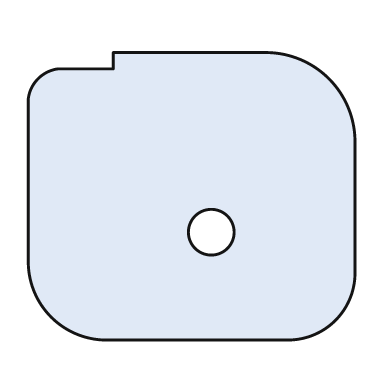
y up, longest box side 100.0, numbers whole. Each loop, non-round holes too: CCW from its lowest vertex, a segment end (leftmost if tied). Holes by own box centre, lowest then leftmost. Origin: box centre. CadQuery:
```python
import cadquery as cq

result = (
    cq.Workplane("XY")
    .moveTo(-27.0, -44.0)
    .lineTo(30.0, -44.0)
    .threePointArc((44.0, -38.0), (50.0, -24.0))
    .lineTo(50.0, 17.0)
    .threePointArc((42.0, 36.0), (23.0, 44.0))
    .lineTo(-24.0, 44.0)
    .lineTo(-24.0, 39.0)
    .lineTo(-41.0, 39.0)
    .threePointArc((-47.0, 36.0), (-50.0, 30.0))
    .lineTo(-50.0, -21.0)
    .threePointArc((-43.0, -37.0), (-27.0, -44.0))
    .close()
    .moveTo(6.0, -11.0)
    .circle(7.0)
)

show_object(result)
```